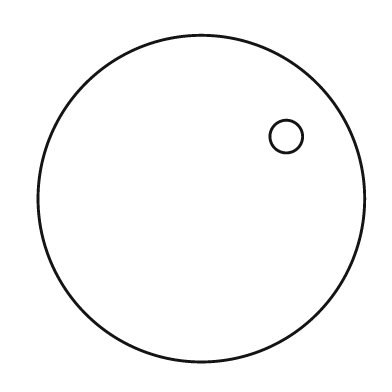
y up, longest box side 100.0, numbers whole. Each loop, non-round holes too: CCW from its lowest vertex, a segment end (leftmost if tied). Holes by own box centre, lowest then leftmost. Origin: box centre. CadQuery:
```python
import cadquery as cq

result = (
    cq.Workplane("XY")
    .moveTo(0.0, 0.0)
    .circle(50.0)
    .moveTo(26.0, 19.0)
    .circle(5.0)
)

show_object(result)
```